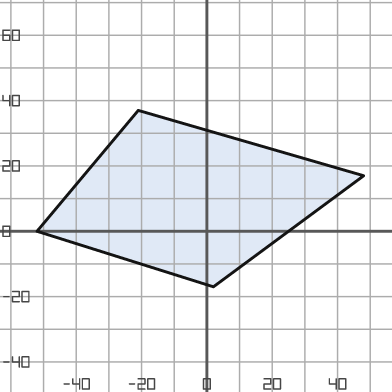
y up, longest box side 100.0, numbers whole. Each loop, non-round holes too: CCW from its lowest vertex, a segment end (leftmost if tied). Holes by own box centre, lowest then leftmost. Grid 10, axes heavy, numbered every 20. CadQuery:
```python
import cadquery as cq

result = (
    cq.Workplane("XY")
    .moveTo(2.0, -17.0)
    .lineTo(48.0, 17.0)
    .lineTo(-21.0, 37.0)
    .lineTo(-52.0, 0.0)
    .close()
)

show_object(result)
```